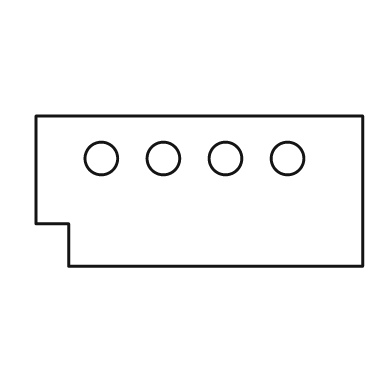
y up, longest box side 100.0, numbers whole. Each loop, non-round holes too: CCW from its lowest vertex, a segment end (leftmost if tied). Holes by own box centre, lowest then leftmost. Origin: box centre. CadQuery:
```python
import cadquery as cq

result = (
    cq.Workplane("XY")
    .moveTo(-40.0, -23.0)
    .lineTo(50.0, -23.0)
    .lineTo(50.0, 23.0)
    .lineTo(-50.0, 23.0)
    .lineTo(-50.0, -10.0)
    .lineTo(-40.0, -10.0)
    .close()
    .moveTo(-30.0, 10.0)
    .circle(5.0)
    .moveTo(-11.0, 10.0)
    .circle(5.0)
    .moveTo(8.0, 10.0)
    .circle(5.0)
    .moveTo(27.0, 10.0)
    .circle(5.0)
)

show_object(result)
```